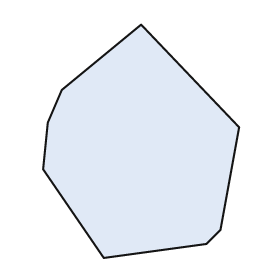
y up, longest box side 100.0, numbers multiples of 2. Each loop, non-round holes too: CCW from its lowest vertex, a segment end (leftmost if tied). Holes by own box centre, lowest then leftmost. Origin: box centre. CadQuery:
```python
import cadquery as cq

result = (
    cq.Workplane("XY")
    .moveTo(-16.0, -50.0)
    .lineTo(28.0, -44.0)
    .lineTo(34.0, -38.0)
    .lineTo(42.0, 6.0)
    .lineTo(0.0, 50.0)
    .lineTo(-34.0, 22.0)
    .lineTo(-40.0, 8.0)
    .lineTo(-42.0, -12.0)
    .close()
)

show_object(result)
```